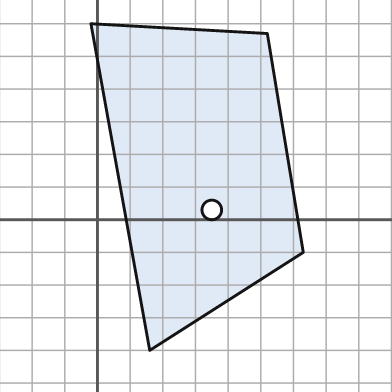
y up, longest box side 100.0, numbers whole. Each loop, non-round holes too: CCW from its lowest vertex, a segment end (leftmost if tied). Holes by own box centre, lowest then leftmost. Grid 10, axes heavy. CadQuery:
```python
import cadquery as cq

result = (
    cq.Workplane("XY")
    .moveTo(16.0, -40.0)
    .lineTo(63.0, -10.0)
    .lineTo(52.0, 57.0)
    .lineTo(-2.0, 60.0)
    .close()
    .moveTo(35.0, 3.0)
    .circle(3.0)
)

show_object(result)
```